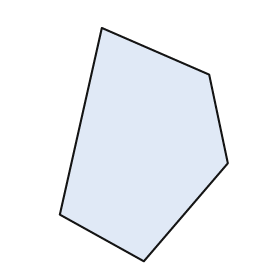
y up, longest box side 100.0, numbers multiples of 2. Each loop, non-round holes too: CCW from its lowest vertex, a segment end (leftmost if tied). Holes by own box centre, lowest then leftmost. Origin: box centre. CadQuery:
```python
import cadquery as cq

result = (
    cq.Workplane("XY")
    .moveTo(0.0, -50.0)
    .lineTo(36.0, -8.0)
    .lineTo(28.0, 30.0)
    .lineTo(-18.0, 50.0)
    .lineTo(-36.0, -30.0)
    .close()
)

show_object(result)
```